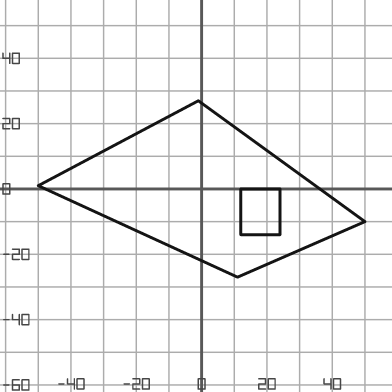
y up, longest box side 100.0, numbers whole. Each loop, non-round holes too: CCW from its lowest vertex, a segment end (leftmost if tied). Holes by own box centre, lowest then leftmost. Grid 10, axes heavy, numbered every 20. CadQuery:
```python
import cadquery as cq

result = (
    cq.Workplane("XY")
    .moveTo(11.0, -27.0)
    .lineTo(50.0, -10.0)
    .lineTo(-1.0, 27.0)
    .lineTo(-50.0, 1.0)
    .close()
    .moveTo(12.0, -14.0)
    .lineTo(24.0, -14.0)
    .lineTo(24.0, 0.0)
    .lineTo(12.0, 0.0)
    .close()
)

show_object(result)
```